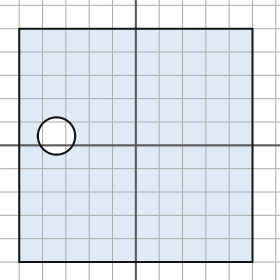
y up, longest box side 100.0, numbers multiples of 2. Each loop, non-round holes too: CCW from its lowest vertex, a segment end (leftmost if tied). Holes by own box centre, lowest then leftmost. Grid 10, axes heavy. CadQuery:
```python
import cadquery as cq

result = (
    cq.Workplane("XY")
    .moveTo(-50.0, -50.0)
    .lineTo(50.0, -50.0)
    .lineTo(50.0, 50.0)
    .lineTo(-50.0, 50.0)
    .close()
    .moveTo(-34.0, 4.0)
    .circle(8.0)
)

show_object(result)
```